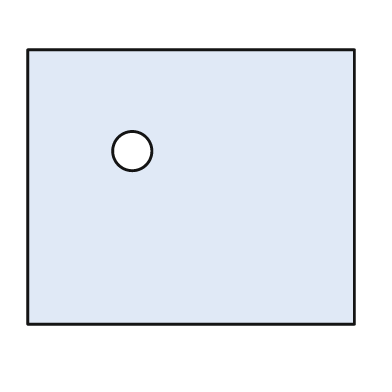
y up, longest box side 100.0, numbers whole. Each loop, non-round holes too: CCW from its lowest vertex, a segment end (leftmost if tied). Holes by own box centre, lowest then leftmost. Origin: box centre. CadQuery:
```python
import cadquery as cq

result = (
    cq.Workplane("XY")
    .moveTo(-50.0, -42.0)
    .lineTo(50.0, -42.0)
    .lineTo(50.0, 42.0)
    .lineTo(-50.0, 42.0)
    .close()
    .moveTo(-18.0, 11.0)
    .circle(6.0)
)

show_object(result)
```